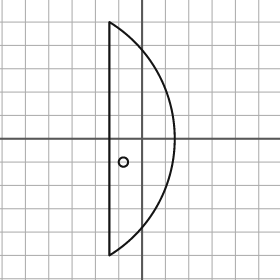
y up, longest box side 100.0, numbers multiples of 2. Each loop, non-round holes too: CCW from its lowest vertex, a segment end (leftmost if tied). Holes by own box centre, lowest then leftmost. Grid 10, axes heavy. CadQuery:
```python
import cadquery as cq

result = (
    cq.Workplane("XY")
    .moveTo(-14.0, -50.0)
    .threePointArc((14.0, 0.0), (-14.0, 50.0))
    .close()
    .moveTo(-8.0, -10.0)
    .circle(2.0)
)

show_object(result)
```